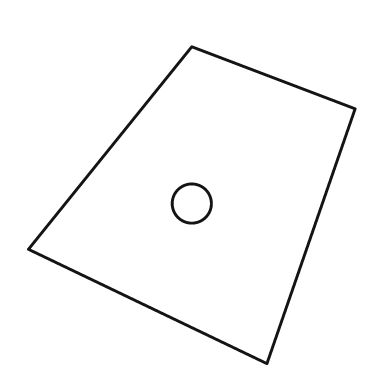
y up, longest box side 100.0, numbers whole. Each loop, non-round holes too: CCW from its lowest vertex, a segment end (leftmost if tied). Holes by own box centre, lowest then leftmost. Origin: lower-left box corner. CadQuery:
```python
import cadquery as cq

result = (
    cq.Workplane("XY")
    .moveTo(73.0, 0.0)
    .lineTo(100.0, 78.0)
    .lineTo(50.0, 97.0)
    .lineTo(0.0, 35.0)
    .close()
    .moveTo(50.0, 49.0)
    .circle(6.0)
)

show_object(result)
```